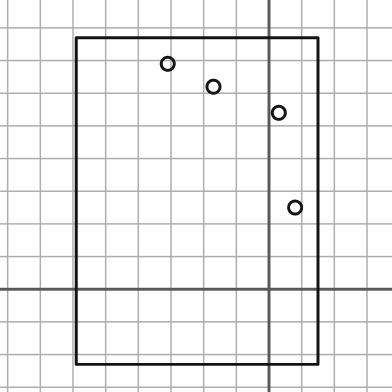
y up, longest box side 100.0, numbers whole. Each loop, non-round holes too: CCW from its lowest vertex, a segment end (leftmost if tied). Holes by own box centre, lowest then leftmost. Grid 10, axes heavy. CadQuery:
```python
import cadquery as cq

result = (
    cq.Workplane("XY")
    .moveTo(-59.0, -23.0)
    .lineTo(15.0, -23.0)
    .lineTo(15.0, 77.0)
    .lineTo(-59.0, 77.0)
    .close()
    .moveTo(8.0, 25.0)
    .circle(2.0)
    .moveTo(3.0, 54.0)
    .circle(2.0)
    .moveTo(-17.0, 62.0)
    .circle(2.0)
    .moveTo(-31.0, 69.0)
    .circle(2.0)
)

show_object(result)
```